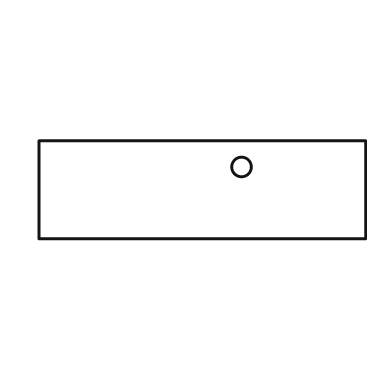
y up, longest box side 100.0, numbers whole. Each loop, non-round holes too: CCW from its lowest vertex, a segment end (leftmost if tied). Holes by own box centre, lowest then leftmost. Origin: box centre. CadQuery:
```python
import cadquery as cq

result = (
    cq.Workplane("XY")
    .moveTo(-50.0, -15.0)
    .lineTo(50.0, -15.0)
    .lineTo(50.0, 15.0)
    .lineTo(-50.0, 15.0)
    .close()
    .moveTo(12.0, 7.0)
    .circle(3.0)
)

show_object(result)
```